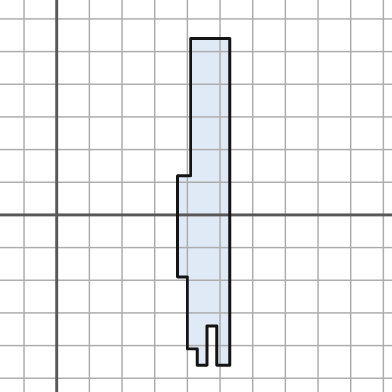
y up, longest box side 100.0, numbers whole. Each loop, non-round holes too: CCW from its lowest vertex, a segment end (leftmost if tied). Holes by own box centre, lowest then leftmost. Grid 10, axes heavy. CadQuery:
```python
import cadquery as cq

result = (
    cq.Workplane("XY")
    .moveTo(43.0, -46.0)
    .lineTo(46.0, -46.0)
    .lineTo(46.0, -34.0)
    .lineTo(49.0, -34.0)
    .lineTo(49.0, -46.0)
    .lineTo(53.0, -46.0)
    .lineTo(53.0, 54.0)
    .lineTo(41.0, 54.0)
    .lineTo(41.0, 12.0)
    .lineTo(37.0, 12.0)
    .lineTo(37.0, -19.0)
    .lineTo(40.0, -19.0)
    .lineTo(40.0, -41.0)
    .lineTo(43.0, -41.0)
    .close()
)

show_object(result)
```